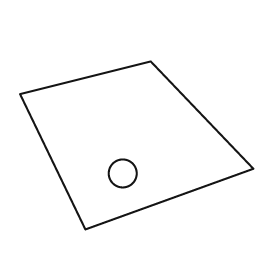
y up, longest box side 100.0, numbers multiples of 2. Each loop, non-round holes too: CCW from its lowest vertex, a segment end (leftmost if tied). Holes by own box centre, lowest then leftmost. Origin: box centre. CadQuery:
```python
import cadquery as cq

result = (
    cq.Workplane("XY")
    .moveTo(-22.0, -36.0)
    .lineTo(50.0, -10.0)
    .lineTo(6.0, 36.0)
    .lineTo(-50.0, 22.0)
    .close()
    .moveTo(-6.0, -12.0)
    .circle(6.0)
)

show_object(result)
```